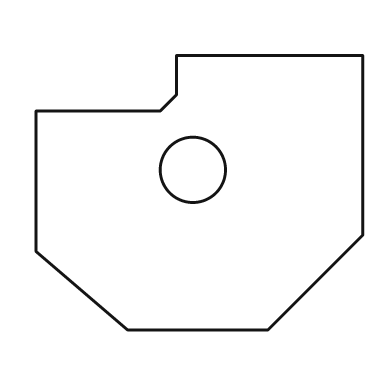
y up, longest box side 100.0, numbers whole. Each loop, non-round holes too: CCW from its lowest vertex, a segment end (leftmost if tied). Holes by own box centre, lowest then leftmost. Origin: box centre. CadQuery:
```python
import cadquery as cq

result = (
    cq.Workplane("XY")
    .moveTo(-22.0, -42.0)
    .lineTo(21.0, -42.0)
    .lineTo(50.0, -13.0)
    .lineTo(50.0, 42.0)
    .lineTo(-7.0, 42.0)
    .lineTo(-7.0, 30.0)
    .lineTo(-12.0, 25.0)
    .lineTo(-50.0, 25.0)
    .lineTo(-50.0, -18.0)
    .close()
    .moveTo(-2.0, 7.0)
    .circle(10.0)
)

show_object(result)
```